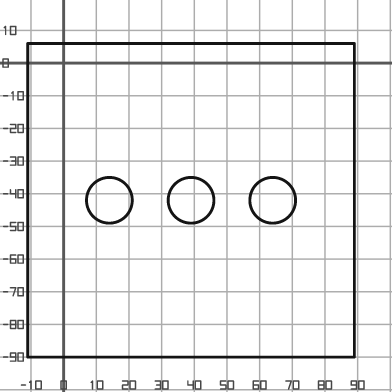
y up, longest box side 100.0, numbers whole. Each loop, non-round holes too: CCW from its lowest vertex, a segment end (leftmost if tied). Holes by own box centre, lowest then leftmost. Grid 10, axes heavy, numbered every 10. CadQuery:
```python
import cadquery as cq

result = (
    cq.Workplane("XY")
    .moveTo(-11.0, -90.0)
    .lineTo(89.0, -90.0)
    .lineTo(89.0, 6.0)
    .lineTo(-11.0, 6.0)
    .close()
    .moveTo(14.0, -42.0)
    .circle(7.0)
    .moveTo(39.0, -42.0)
    .circle(7.0)
    .moveTo(64.0, -42.0)
    .circle(7.0)
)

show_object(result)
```